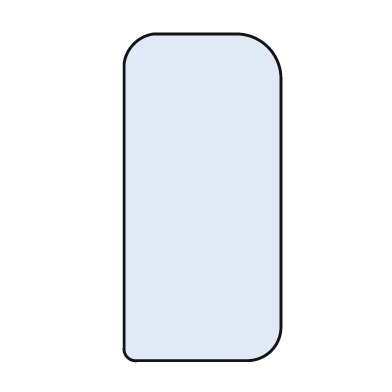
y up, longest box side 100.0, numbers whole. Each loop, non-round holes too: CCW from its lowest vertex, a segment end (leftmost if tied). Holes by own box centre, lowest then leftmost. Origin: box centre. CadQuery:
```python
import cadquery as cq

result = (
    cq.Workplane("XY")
    .moveTo(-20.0, -50.0)
    .lineTo(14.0, -50.0)
    .threePointArc((21.0, -47.0), (24.0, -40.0))
    .lineTo(24.0, 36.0)
    .threePointArc((20.0, 46.0), (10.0, 50.0))
    .lineTo(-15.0, 50.0)
    .threePointArc((-21.0, 47.0), (-24.0, 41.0))
    .lineTo(-24.0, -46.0)
    .threePointArc((-23.0, -49.0), (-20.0, -50.0))
    .close()
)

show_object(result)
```